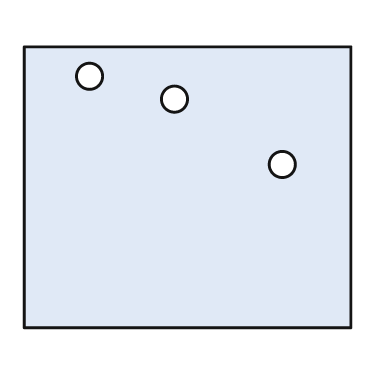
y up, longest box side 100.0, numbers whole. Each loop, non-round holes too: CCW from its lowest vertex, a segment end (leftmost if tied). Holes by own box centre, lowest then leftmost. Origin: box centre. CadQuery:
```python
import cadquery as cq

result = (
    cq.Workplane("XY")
    .moveTo(-50.0, -43.0)
    .lineTo(50.0, -43.0)
    .lineTo(50.0, 43.0)
    .lineTo(-50.0, 43.0)
    .close()
    .moveTo(29.0, 7.0)
    .circle(4.0)
    .moveTo(-4.0, 27.0)
    .circle(4.0)
    .moveTo(-30.0, 34.0)
    .circle(4.0)
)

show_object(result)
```